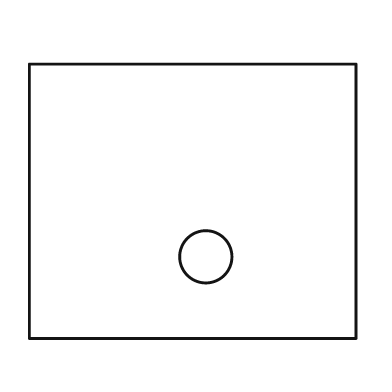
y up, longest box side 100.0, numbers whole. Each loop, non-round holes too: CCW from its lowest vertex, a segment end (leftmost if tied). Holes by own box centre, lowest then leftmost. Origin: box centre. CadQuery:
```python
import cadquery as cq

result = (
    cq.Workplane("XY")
    .moveTo(-50.0, -42.0)
    .lineTo(50.0, -42.0)
    .lineTo(50.0, 42.0)
    .lineTo(-50.0, 42.0)
    .close()
    .moveTo(4.0, -17.0)
    .circle(8.0)
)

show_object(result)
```